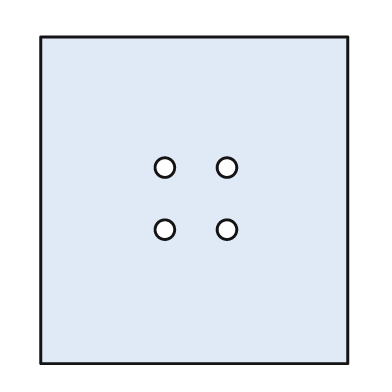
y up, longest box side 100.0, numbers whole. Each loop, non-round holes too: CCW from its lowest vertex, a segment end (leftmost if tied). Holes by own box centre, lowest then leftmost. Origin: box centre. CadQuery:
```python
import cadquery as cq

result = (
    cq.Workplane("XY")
    .moveTo(-47.0, -50.0)
    .lineTo(47.0, -50.0)
    .lineTo(47.0, 50.0)
    .lineTo(-47.0, 50.0)
    .close()
    .moveTo(-9.0, -9.0)
    .circle(3.0)
    .moveTo(10.0, -9.0)
    .circle(3.0)
    .moveTo(-9.0, 10.0)
    .circle(3.0)
    .moveTo(10.0, 10.0)
    .circle(3.0)
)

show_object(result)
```